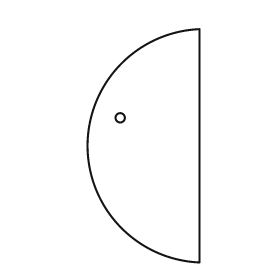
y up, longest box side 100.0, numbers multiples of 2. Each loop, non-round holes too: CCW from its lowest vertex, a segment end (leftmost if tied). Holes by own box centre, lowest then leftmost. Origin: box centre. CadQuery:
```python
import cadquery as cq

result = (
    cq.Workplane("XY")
    .moveTo(24.0, -50.0)
    .lineTo(24.0, 50.0)
    .threePointArc((-24.0, 0.0), (24.0, -50.0))
    .close()
    .moveTo(-10.0, 12.0)
    .circle(2.0)
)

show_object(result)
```